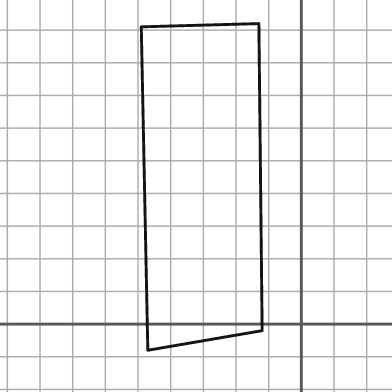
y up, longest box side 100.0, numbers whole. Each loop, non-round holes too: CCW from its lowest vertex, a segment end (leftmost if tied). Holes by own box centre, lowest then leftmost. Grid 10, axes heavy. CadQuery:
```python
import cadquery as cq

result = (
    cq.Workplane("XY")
    .moveTo(-47.0, -8.0)
    .lineTo(-12.0, -2.0)
    .lineTo(-13.0, 92.0)
    .lineTo(-49.0, 91.0)
    .close()
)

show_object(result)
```